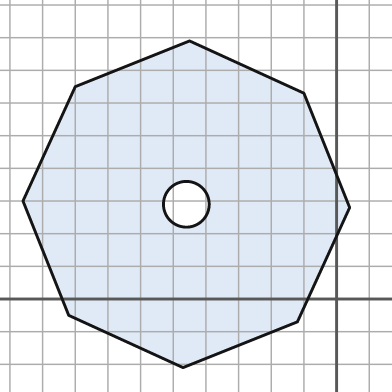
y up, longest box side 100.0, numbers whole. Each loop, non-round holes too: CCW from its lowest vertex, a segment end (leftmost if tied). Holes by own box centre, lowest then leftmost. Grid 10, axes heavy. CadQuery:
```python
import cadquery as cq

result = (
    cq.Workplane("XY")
    .moveTo(-47.0, -21.0)
    .lineTo(-12.0, -7.0)
    .lineTo(4.0, 28.0)
    .lineTo(-10.0, 63.0)
    .lineTo(-45.0, 79.0)
    .lineTo(-80.0, 65.0)
    .lineTo(-96.0, 30.0)
    .lineTo(-82.0, -5.0)
    .close()
    .moveTo(-46.0, 29.0)
    .circle(7.0)
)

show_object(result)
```